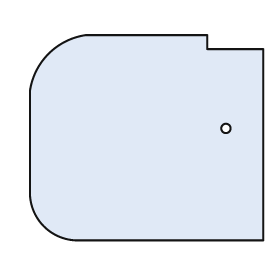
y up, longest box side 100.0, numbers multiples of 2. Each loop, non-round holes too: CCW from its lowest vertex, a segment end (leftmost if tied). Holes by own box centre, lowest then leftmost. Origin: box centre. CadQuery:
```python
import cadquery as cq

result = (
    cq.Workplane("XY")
    .moveTo(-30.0, -44.0)
    .lineTo(50.0, -44.0)
    .lineTo(50.0, 38.0)
    .lineTo(26.0, 38.0)
    .lineTo(26.0, 44.0)
    .lineTo(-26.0, 44.0)
    .threePointArc((-42.0, 36.0), (-50.0, 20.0))
    .lineTo(-50.0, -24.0)
    .threePointArc((-44.0, -38.0), (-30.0, -44.0))
    .close()
    .moveTo(34.0, 4.0)
    .circle(2.0)
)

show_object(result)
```